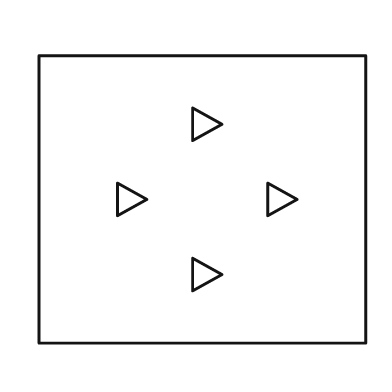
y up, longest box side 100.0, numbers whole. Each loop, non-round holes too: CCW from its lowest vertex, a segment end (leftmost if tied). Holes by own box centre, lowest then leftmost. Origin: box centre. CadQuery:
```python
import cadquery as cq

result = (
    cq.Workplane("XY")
    .moveTo(-50.0, -44.0)
    .lineTo(50.0, -44.0)
    .lineTo(50.0, 44.0)
    .lineTo(-50.0, 44.0)
    .close()
    .moveTo(-3.0, -28.0)
    .lineTo(6.0, -23.0)
    .lineTo(-3.0, -18.0)
    .close()
    .moveTo(-26.0, -5.0)
    .lineTo(-17.0, 0.0)
    .lineTo(-26.0, 5.0)
    .close()
    .moveTo(20.0, -5.0)
    .lineTo(29.0, 0.0)
    .lineTo(20.0, 5.0)
    .close()
    .moveTo(-3.0, 18.0)
    .lineTo(6.0, 23.0)
    .lineTo(-3.0, 28.0)
    .close()
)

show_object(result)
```